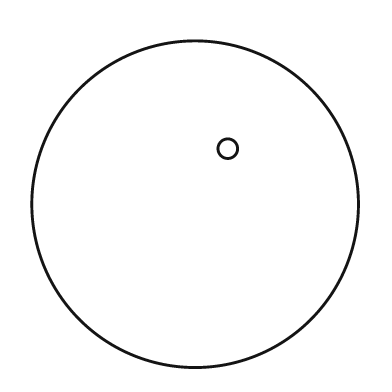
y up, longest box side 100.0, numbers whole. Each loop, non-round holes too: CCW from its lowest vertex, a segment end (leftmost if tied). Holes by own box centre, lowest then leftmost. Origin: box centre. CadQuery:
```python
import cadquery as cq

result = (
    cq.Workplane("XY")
    .moveTo(0.0, 0.0)
    .circle(50.0)
    .moveTo(10.0, 17.0)
    .circle(3.0)
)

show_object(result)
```